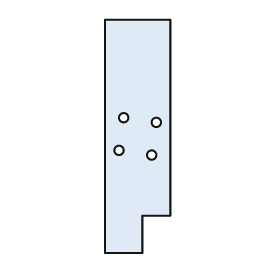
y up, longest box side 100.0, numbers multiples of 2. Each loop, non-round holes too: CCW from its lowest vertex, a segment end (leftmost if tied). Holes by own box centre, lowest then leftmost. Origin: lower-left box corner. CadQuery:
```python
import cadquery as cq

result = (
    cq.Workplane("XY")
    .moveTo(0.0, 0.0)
    .lineTo(16.0, 0.0)
    .lineTo(16.0, 16.0)
    .lineTo(28.0, 16.0)
    .lineTo(28.0, 100.0)
    .lineTo(0.0, 100.0)
    .close()
    .moveTo(20.0, 42.0)
    .circle(2.0)
    .moveTo(6.0, 44.0)
    .circle(2.0)
    .moveTo(22.0, 56.0)
    .circle(2.0)
    .moveTo(8.0, 58.0)
    .circle(2.0)
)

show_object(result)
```